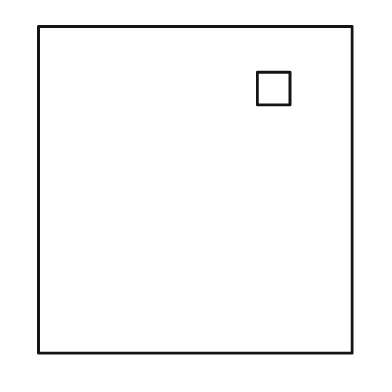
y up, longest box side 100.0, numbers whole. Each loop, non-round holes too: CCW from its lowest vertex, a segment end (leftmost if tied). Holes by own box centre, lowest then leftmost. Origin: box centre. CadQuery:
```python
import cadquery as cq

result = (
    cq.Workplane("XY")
    .moveTo(-48.0, -50.0)
    .lineTo(48.0, -50.0)
    .lineTo(48.0, 50.0)
    .lineTo(-48.0, 50.0)
    .close()
    .moveTo(19.0, 26.0)
    .lineTo(29.0, 26.0)
    .lineTo(29.0, 36.0)
    .lineTo(19.0, 36.0)
    .close()
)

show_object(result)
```